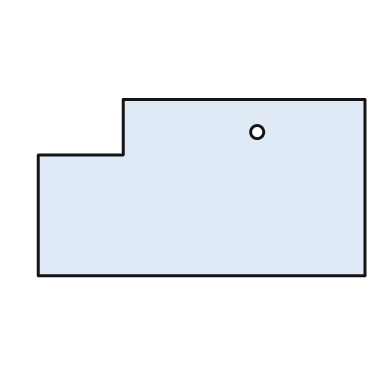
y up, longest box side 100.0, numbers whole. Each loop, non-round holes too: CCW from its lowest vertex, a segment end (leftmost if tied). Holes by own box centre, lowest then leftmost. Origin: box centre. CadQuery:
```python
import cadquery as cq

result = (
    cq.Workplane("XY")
    .moveTo(-50.0, -27.0)
    .lineTo(50.0, -27.0)
    .lineTo(50.0, 27.0)
    .lineTo(-24.0, 27.0)
    .lineTo(-24.0, 10.0)
    .lineTo(-50.0, 10.0)
    .close()
    .moveTo(17.0, 17.0)
    .circle(2.0)
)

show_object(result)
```